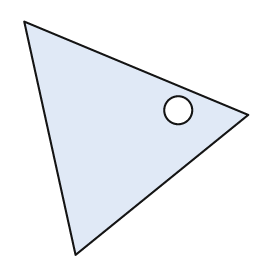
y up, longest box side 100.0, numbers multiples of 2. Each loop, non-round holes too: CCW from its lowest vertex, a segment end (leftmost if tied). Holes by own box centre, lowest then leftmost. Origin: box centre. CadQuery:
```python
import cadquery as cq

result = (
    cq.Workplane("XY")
    .moveTo(-26.0, -50.0)
    .lineTo(48.0, 10.0)
    .lineTo(-48.0, 50.0)
    .close()
    .moveTo(18.0, 12.0)
    .circle(6.0)
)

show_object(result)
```